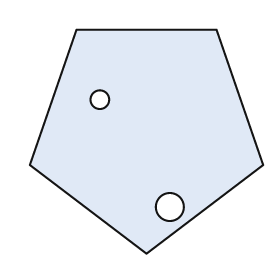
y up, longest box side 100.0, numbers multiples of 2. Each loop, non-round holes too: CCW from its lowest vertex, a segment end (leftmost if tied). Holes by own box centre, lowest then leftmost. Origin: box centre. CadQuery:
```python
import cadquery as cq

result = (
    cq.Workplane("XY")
    .moveTo(0.0, -48.0)
    .lineTo(50.0, -10.0)
    .lineTo(30.0, 48.0)
    .lineTo(-30.0, 48.0)
    .lineTo(-50.0, -10.0)
    .close()
    .moveTo(10.0, -28.0)
    .circle(6.0)
    .moveTo(-20.0, 18.0)
    .circle(4.0)
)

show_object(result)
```